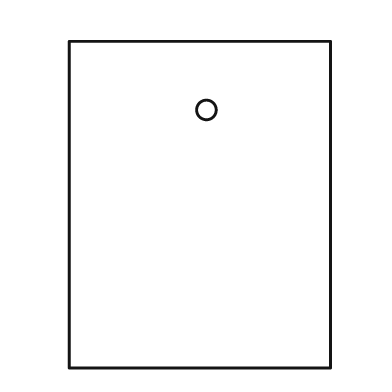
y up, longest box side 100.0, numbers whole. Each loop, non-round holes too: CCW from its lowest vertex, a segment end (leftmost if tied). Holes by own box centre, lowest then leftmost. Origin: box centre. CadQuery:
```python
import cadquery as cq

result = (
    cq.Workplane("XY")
    .moveTo(-40.0, -50.0)
    .lineTo(40.0, -50.0)
    .lineTo(40.0, 50.0)
    .lineTo(-40.0, 50.0)
    .close()
    .moveTo(2.0, 29.0)
    .circle(3.0)
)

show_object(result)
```